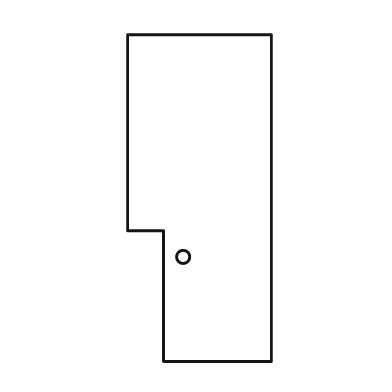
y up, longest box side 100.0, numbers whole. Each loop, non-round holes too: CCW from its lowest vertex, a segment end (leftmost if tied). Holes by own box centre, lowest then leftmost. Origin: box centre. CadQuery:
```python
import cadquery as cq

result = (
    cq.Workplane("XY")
    .moveTo(-11.0, -50.0)
    .lineTo(22.0, -50.0)
    .lineTo(22.0, 50.0)
    .lineTo(-22.0, 50.0)
    .lineTo(-22.0, -10.0)
    .lineTo(-11.0, -10.0)
    .close()
    .moveTo(-5.0, -18.0)
    .circle(2.0)
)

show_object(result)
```